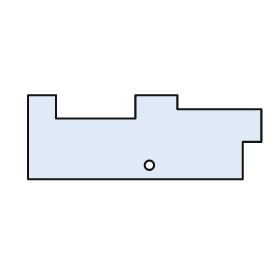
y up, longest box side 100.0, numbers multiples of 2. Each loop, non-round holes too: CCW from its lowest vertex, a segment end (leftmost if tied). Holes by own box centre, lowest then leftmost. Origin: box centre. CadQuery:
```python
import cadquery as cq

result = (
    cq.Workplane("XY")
    .moveTo(-50.0, -18.0)
    .lineTo(42.0, -18.0)
    .lineTo(42.0, -2.0)
    .lineTo(50.0, -2.0)
    .lineTo(50.0, 12.0)
    .lineTo(14.0, 12.0)
    .lineTo(14.0, 18.0)
    .lineTo(-4.0, 18.0)
    .lineTo(-4.0, 8.0)
    .lineTo(-38.0, 8.0)
    .lineTo(-38.0, 18.0)
    .lineTo(-50.0, 18.0)
    .close()
    .moveTo(2.0, -12.0)
    .circle(2.0)
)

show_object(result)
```